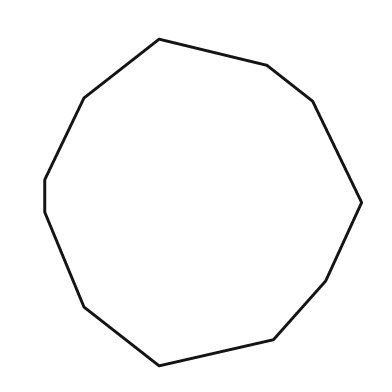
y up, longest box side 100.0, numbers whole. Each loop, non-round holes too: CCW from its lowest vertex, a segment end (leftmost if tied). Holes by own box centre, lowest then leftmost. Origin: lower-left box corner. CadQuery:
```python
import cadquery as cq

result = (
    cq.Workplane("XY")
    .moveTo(35.0, 0.0)
    .lineTo(70.0, 8.0)
    .lineTo(86.0, 26.0)
    .lineTo(97.0, 50.0)
    .lineTo(82.0, 81.0)
    .lineTo(68.0, 92.0)
    .lineTo(35.0, 100.0)
    .lineTo(12.0, 82.0)
    .lineTo(0.0, 57.0)
    .lineTo(0.0, 47.0)
    .lineTo(12.0, 18.0)
    .close()
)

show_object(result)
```